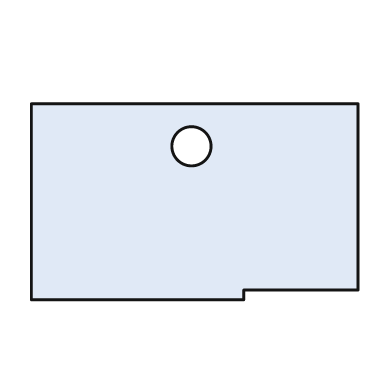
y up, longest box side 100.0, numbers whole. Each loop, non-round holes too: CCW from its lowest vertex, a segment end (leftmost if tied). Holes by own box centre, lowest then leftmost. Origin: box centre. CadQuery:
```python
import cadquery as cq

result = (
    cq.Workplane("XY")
    .moveTo(-50.0, -30.0)
    .lineTo(15.0, -30.0)
    .lineTo(15.0, -27.0)
    .lineTo(50.0, -27.0)
    .lineTo(50.0, 30.0)
    .lineTo(-50.0, 30.0)
    .close()
    .moveTo(-1.0, 17.0)
    .circle(6.0)
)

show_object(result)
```